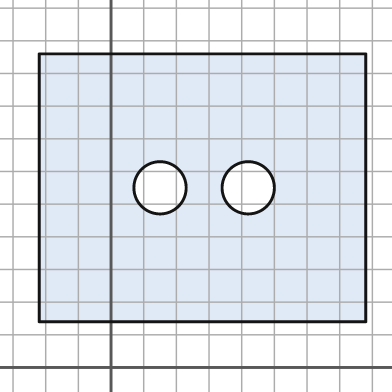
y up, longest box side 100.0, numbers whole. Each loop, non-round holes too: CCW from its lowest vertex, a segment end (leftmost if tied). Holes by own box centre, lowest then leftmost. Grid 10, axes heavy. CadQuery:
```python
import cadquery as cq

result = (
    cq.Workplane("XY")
    .moveTo(-22.0, 14.0)
    .lineTo(78.0, 14.0)
    .lineTo(78.0, 96.0)
    .lineTo(-22.0, 96.0)
    .close()
    .moveTo(15.0, 55.0)
    .circle(8.0)
    .moveTo(42.0, 55.0)
    .circle(8.0)
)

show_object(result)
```